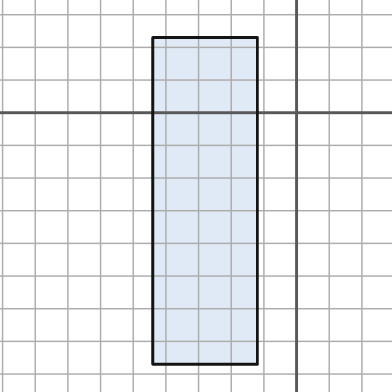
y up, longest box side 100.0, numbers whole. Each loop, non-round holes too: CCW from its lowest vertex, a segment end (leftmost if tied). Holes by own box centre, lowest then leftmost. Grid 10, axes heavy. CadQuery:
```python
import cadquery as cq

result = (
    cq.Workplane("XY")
    .moveTo(-44.0, -77.0)
    .lineTo(-12.0, -77.0)
    .lineTo(-12.0, 23.0)
    .lineTo(-44.0, 23.0)
    .close()
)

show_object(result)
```